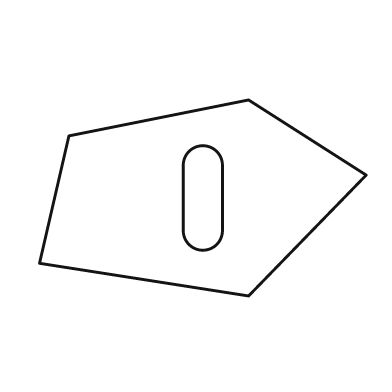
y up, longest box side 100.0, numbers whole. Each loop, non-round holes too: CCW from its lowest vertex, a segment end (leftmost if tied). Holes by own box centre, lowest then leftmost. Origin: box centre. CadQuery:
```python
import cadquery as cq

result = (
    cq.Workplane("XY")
    .moveTo(14.0, -30.0)
    .lineTo(50.0, 7.0)
    .lineTo(14.0, 30.0)
    .lineTo(-41.0, 19.0)
    .lineTo(-50.0, -20.0)
    .close()
    .moveTo(-6.0, -10.0)
    .threePointArc((0.0, -16.0), (6.0, -10.0))
    .lineTo(6.0, 10.0)
    .threePointArc((0.0, 16.0), (-6.0, 10.0))
    .close()
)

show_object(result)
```